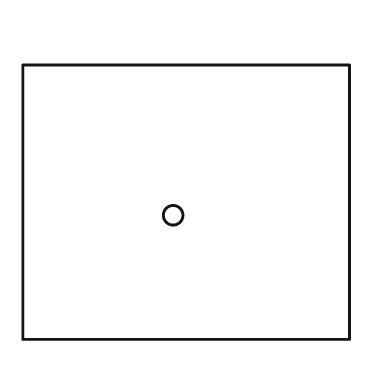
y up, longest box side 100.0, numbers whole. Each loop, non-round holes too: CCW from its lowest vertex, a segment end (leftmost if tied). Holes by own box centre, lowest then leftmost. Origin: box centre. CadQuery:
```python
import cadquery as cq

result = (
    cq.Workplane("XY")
    .moveTo(-50.0, -42.0)
    .lineTo(50.0, -42.0)
    .lineTo(50.0, 42.0)
    .lineTo(-50.0, 42.0)
    .close()
    .moveTo(-4.0, -4.0)
    .circle(3.0)
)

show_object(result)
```